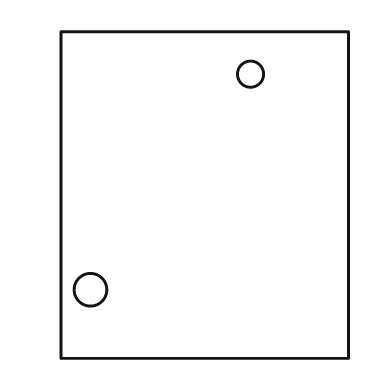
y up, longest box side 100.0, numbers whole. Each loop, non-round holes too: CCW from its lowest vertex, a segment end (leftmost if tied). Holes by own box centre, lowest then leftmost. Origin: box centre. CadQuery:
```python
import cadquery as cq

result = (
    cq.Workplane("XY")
    .moveTo(-44.0, -50.0)
    .lineTo(44.0, -50.0)
    .lineTo(44.0, 50.0)
    .lineTo(-44.0, 50.0)
    .close()
    .moveTo(-35.0, -29.0)
    .circle(5.0)
    .moveTo(14.0, 37.0)
    .circle(4.0)
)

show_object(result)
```